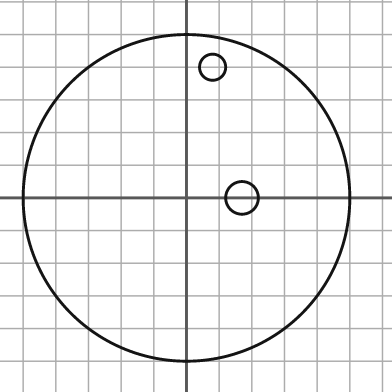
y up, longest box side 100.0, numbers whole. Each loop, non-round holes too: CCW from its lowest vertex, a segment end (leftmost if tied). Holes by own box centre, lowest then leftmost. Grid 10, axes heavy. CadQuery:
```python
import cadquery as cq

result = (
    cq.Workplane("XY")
    .moveTo(0.0, 0.0)
    .circle(50.0)
    .moveTo(17.0, 0.0)
    .circle(5.0)
    .moveTo(8.0, 40.0)
    .circle(4.0)
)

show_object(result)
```